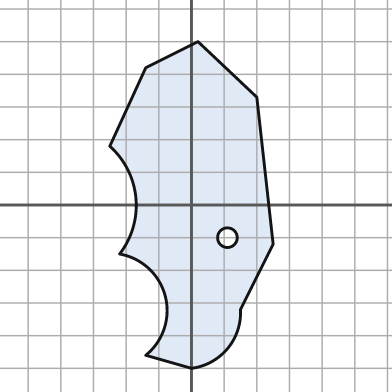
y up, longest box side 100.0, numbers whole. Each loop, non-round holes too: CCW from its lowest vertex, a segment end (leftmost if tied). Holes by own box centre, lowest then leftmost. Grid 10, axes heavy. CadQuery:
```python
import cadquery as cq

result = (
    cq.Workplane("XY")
    .moveTo(0.0, -50.0)
    .threePointArc((11.0, -44.0), (15.0, -32.0))
    .lineTo(25.0, -12.0)
    .lineTo(20.0, 33.0)
    .lineTo(2.0, 50.0)
    .lineTo(-14.0, 42.0)
    .lineTo(-25.0, 18.0)
    .threePointArc((-17.0, 2.0), (-22.0, -15.0))
    .threePointArc((-8.0, -28.0), (-14.0, -46.0))
    .close()
    .moveTo(11.0, -10.0)
    .circle(3.0)
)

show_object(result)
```